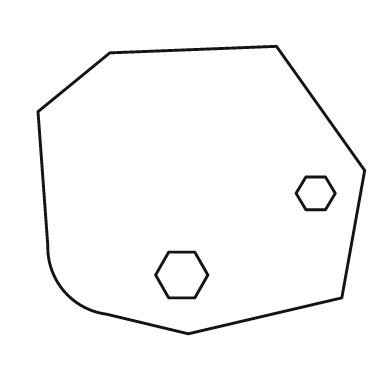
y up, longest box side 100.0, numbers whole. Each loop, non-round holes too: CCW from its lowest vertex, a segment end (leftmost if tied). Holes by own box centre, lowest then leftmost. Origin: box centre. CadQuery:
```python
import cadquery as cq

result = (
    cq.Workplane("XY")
    .moveTo(-4.0, -44.0)
    .lineTo(43.0, -33.0)
    .lineTo(50.0, 6.0)
    .lineTo(23.0, 44.0)
    .lineTo(-28.0, 42.0)
    .lineTo(-50.0, 24.0)
    .lineTo(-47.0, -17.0)
    .threePointArc((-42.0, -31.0), (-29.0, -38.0))
    .close()
    .moveTo(-10.0, -33.0)
    .lineTo(-2.0, -33.0)
    .lineTo(2.0, -26.0)
    .lineTo(-2.0, -19.0)
    .lineTo(-10.0, -19.0)
    .lineTo(-14.0, -26.0)
    .close()
    .moveTo(32.0, -6.0)
    .lineTo(38.0, -6.0)
    .lineTo(41.0, -1.0)
    .lineTo(38.0, 4.0)
    .lineTo(32.0, 4.0)
    .lineTo(29.0, -1.0)
    .close()
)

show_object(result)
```